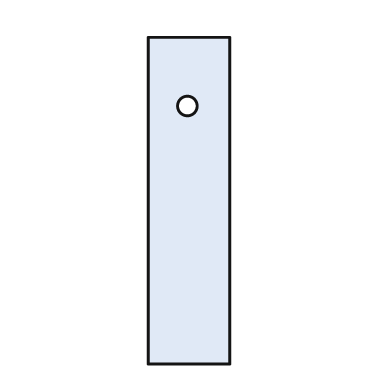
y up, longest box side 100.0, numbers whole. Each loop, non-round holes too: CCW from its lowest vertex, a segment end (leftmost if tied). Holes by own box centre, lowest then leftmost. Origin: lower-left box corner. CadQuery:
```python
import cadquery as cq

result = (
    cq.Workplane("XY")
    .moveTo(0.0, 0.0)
    .lineTo(25.0, 0.0)
    .lineTo(25.0, 100.0)
    .lineTo(0.0, 100.0)
    .close()
    .moveTo(12.0, 79.0)
    .circle(3.0)
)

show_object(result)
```